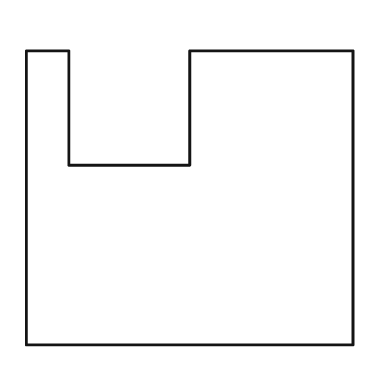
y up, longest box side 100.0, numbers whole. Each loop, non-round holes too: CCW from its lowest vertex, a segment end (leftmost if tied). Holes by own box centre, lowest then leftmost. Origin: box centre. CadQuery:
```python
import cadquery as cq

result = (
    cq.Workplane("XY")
    .moveTo(-50.0, -45.0)
    .lineTo(50.0, -45.0)
    .lineTo(50.0, 45.0)
    .lineTo(0.0, 45.0)
    .lineTo(0.0, 10.0)
    .lineTo(-37.0, 10.0)
    .lineTo(-37.0, 45.0)
    .lineTo(-50.0, 45.0)
    .close()
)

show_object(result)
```